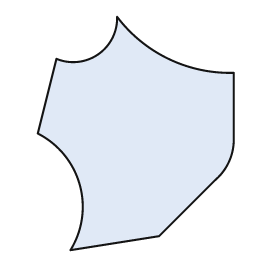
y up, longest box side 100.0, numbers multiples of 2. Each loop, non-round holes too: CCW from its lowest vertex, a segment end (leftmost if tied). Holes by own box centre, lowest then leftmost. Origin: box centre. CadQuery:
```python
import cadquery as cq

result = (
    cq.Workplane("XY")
    .moveTo(-28.0, -50.0)
    .lineTo(10.0, -44.0)
    .lineTo(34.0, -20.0)
    .threePointArc((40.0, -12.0), (42.0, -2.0))
    .lineTo(42.0, 26.0)
    .threePointArc((14.0, 32.0), (-8.0, 50.0))
    .threePointArc((-16.0, 34.0), (-34.0, 32.0))
    .lineTo(-42.0, 0.0)
    .threePointArc((-24.0, -22.0), (-28.0, -50.0))
    .close()
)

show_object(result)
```